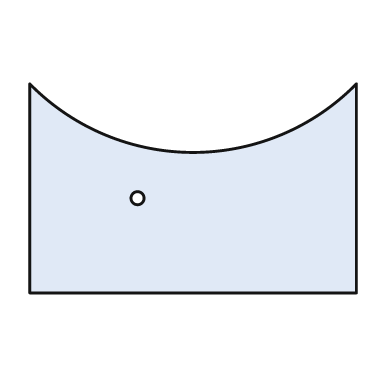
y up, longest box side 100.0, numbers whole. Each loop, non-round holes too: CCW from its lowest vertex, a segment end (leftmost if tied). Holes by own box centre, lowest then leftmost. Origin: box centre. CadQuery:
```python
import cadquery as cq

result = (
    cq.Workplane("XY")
    .moveTo(-50.0, -32.0)
    .lineTo(50.0, -32.0)
    .lineTo(50.0, 32.0)
    .threePointArc((0.0, 11.0), (-50.0, 32.0))
    .close()
    .moveTo(-17.0, -3.0)
    .circle(2.0)
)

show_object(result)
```